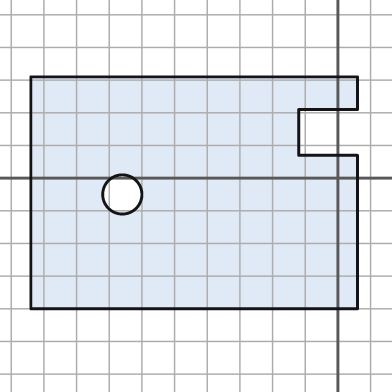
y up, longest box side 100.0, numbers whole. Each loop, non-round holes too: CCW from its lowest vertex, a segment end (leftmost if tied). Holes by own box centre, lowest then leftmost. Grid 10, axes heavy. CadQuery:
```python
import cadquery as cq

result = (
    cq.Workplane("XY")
    .moveTo(-94.0, -40.0)
    .lineTo(6.0, -40.0)
    .lineTo(6.0, 7.0)
    .lineTo(-12.0, 7.0)
    .lineTo(-12.0, 21.0)
    .lineTo(6.0, 21.0)
    .lineTo(6.0, 31.0)
    .lineTo(-94.0, 31.0)
    .close()
    .moveTo(-66.0, -5.0)
    .circle(6.0)
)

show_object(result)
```